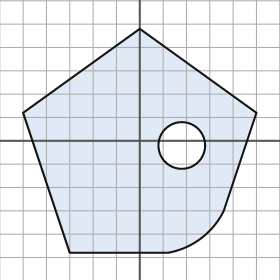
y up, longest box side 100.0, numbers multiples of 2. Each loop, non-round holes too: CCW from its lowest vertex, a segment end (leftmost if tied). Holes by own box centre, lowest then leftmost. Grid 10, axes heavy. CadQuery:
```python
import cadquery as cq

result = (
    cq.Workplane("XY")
    .moveTo(-30.0, -48.0)
    .lineTo(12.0, -48.0)
    .threePointArc((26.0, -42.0), (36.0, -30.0))
    .lineTo(50.0, 12.0)
    .lineTo(0.0, 48.0)
    .lineTo(-50.0, 12.0)
    .close()
    .moveTo(18.0, -2.0)
    .circle(10.0)
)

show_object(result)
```